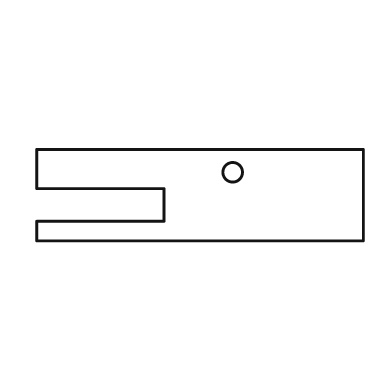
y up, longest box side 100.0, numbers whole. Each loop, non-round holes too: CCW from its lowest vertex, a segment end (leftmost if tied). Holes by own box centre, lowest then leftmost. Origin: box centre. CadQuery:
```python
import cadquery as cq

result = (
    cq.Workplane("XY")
    .moveTo(-50.0, -14.0)
    .lineTo(50.0, -14.0)
    .lineTo(50.0, 14.0)
    .lineTo(-50.0, 14.0)
    .lineTo(-50.0, 2.0)
    .lineTo(-11.0, 2.0)
    .lineTo(-11.0, -8.0)
    .lineTo(-50.0, -8.0)
    .close()
    .moveTo(10.0, 7.0)
    .circle(3.0)
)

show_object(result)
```